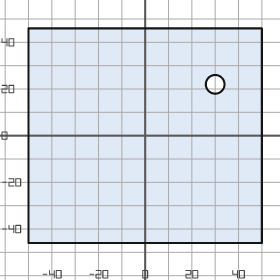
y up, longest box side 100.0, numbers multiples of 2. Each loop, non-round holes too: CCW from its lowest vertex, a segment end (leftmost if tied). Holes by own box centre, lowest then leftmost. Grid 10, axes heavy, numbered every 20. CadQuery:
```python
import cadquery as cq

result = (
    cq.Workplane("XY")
    .moveTo(-50.0, -46.0)
    .lineTo(50.0, -46.0)
    .lineTo(50.0, 46.0)
    .lineTo(-50.0, 46.0)
    .close()
    .moveTo(30.0, 22.0)
    .circle(4.0)
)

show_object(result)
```